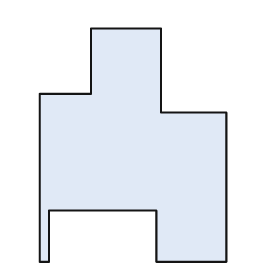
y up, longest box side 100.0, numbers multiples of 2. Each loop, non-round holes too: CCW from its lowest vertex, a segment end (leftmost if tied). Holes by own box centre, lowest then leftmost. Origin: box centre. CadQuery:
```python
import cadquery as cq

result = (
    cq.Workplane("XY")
    .moveTo(-40.0, -50.0)
    .lineTo(-36.0, -50.0)
    .lineTo(-36.0, -28.0)
    .lineTo(10.0, -28.0)
    .lineTo(10.0, -50.0)
    .lineTo(40.0, -50.0)
    .lineTo(40.0, 14.0)
    .lineTo(12.0, 14.0)
    .lineTo(12.0, 50.0)
    .lineTo(-18.0, 50.0)
    .lineTo(-18.0, 22.0)
    .lineTo(-40.0, 22.0)
    .close()
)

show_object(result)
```